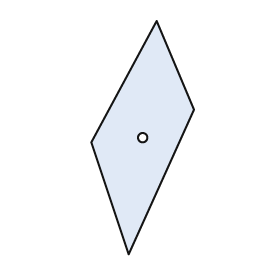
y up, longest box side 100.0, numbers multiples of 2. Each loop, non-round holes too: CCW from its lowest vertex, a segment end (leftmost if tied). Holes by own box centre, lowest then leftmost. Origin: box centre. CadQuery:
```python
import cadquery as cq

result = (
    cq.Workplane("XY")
    .moveTo(-6.0, -50.0)
    .lineTo(22.0, 12.0)
    .lineTo(6.0, 50.0)
    .lineTo(-22.0, -2.0)
    .close()
    .moveTo(0.0, 0.0)
    .circle(2.0)
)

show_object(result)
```